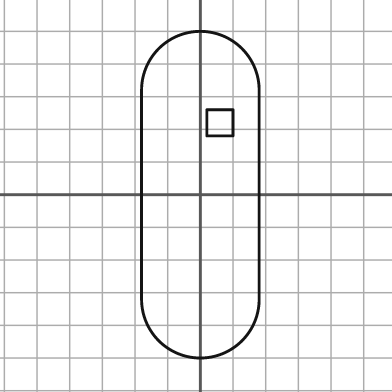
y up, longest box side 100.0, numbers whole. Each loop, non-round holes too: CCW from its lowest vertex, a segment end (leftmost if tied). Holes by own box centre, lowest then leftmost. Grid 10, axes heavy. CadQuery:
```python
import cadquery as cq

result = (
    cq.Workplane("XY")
    .moveTo(-18.0, -32.0)
    .threePointArc((0.0, -50.0), (18.0, -32.0))
    .lineTo(18.0, 32.0)
    .threePointArc((0.0, 50.0), (-18.0, 32.0))
    .close()
    .moveTo(2.0, 18.0)
    .lineTo(10.0, 18.0)
    .lineTo(10.0, 26.0)
    .lineTo(2.0, 26.0)
    .close()
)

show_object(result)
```